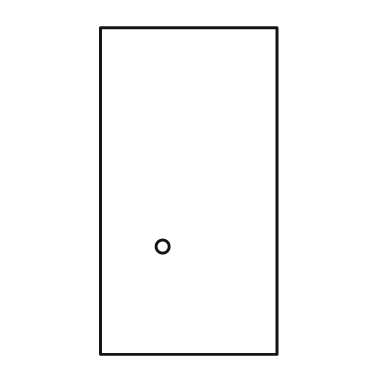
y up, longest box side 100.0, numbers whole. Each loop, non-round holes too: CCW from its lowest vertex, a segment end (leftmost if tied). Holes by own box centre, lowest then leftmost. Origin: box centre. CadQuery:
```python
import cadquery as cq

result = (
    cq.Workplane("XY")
    .moveTo(-27.0, -50.0)
    .lineTo(27.0, -50.0)
    .lineTo(27.0, 50.0)
    .lineTo(-27.0, 50.0)
    .close()
    .moveTo(-8.0, -17.0)
    .circle(2.0)
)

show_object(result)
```